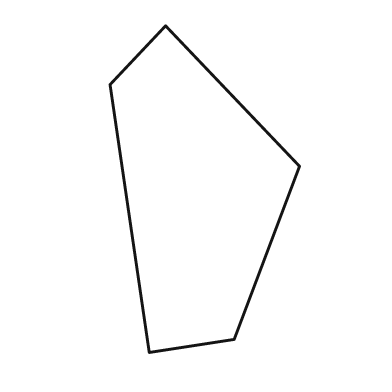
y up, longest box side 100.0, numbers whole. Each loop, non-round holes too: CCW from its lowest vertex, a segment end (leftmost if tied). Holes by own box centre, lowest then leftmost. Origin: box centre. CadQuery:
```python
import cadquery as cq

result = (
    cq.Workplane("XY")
    .moveTo(-17.0, -50.0)
    .lineTo(9.0, -46.0)
    .lineTo(29.0, 7.0)
    .lineTo(-12.0, 50.0)
    .lineTo(-29.0, 32.0)
    .close()
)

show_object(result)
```